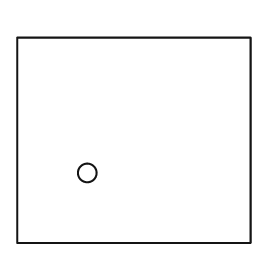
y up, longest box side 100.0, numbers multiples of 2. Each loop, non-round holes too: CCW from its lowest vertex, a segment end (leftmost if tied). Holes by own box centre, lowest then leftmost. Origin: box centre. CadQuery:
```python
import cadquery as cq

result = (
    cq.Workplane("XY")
    .moveTo(-50.0, -44.0)
    .lineTo(50.0, -44.0)
    .lineTo(50.0, 44.0)
    .lineTo(-50.0, 44.0)
    .close()
    .moveTo(-20.0, -14.0)
    .circle(4.0)
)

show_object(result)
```